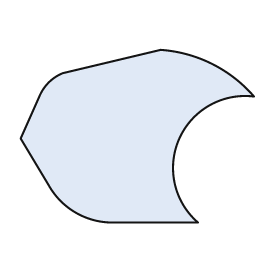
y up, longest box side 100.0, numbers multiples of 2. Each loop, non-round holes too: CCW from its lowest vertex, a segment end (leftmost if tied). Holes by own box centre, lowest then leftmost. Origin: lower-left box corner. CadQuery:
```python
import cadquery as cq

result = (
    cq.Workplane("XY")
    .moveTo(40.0, 0.0)
    .lineTo(76.0, 0.0)
    .threePointArc((68.0, 36.0), (100.0, 54.0))
    .threePointArc((82.0, 68.0), (60.0, 74.0))
    .lineTo(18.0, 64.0)
    .threePointArc((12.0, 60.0), (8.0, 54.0))
    .lineTo(0.0, 36.0)
    .lineTo(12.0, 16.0)
    .threePointArc((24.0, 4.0), (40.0, 0.0))
    .close()
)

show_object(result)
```